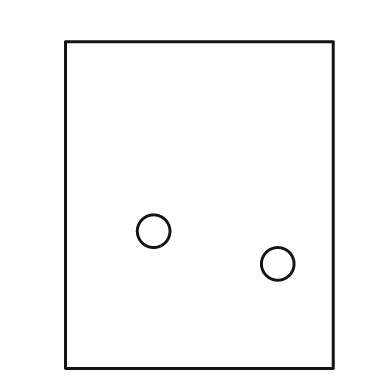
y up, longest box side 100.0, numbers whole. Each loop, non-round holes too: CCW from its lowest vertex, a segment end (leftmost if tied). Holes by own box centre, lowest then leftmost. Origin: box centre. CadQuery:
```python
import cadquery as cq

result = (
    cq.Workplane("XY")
    .moveTo(-41.0, -50.0)
    .lineTo(41.0, -50.0)
    .lineTo(41.0, 50.0)
    .lineTo(-41.0, 50.0)
    .close()
    .moveTo(24.0, -18.0)
    .circle(5.0)
    .moveTo(-14.0, -8.0)
    .circle(5.0)
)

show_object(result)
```